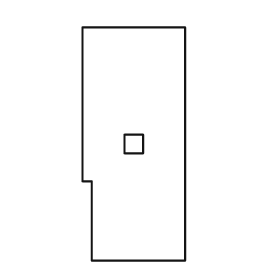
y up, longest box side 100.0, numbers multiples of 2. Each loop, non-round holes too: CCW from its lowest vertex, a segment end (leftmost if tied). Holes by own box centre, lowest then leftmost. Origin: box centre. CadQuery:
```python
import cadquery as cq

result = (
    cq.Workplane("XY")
    .moveTo(-18.0, -50.0)
    .lineTo(22.0, -50.0)
    .lineTo(22.0, 50.0)
    .lineTo(-22.0, 50.0)
    .lineTo(-22.0, -16.0)
    .lineTo(-18.0, -16.0)
    .close()
    .moveTo(-4.0, -4.0)
    .lineTo(4.0, -4.0)
    .lineTo(4.0, 4.0)
    .lineTo(-4.0, 4.0)
    .close()
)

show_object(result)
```